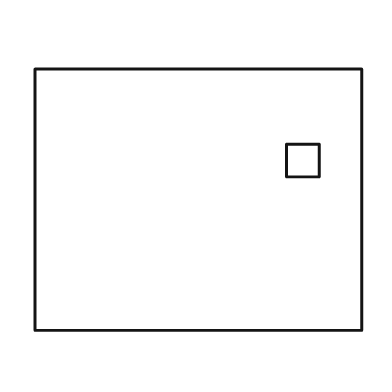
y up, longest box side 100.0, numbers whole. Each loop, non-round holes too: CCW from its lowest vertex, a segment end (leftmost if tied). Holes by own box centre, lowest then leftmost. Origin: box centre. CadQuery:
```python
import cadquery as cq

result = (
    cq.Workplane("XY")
    .moveTo(-50.0, -40.0)
    .lineTo(50.0, -40.0)
    .lineTo(50.0, 40.0)
    .lineTo(-50.0, 40.0)
    .close()
    .moveTo(27.0, 7.0)
    .lineTo(37.0, 7.0)
    .lineTo(37.0, 17.0)
    .lineTo(27.0, 17.0)
    .close()
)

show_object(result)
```